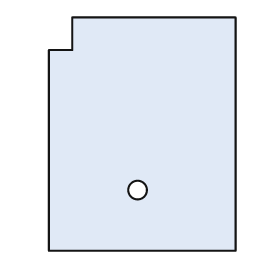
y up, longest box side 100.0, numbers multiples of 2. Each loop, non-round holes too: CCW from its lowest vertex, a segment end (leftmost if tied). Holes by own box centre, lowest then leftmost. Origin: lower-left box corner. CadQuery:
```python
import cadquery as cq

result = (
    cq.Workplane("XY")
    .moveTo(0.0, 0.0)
    .lineTo(80.0, 0.0)
    .lineTo(80.0, 100.0)
    .lineTo(10.0, 100.0)
    .lineTo(10.0, 86.0)
    .lineTo(0.0, 86.0)
    .close()
    .moveTo(38.0, 26.0)
    .circle(4.0)
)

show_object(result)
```